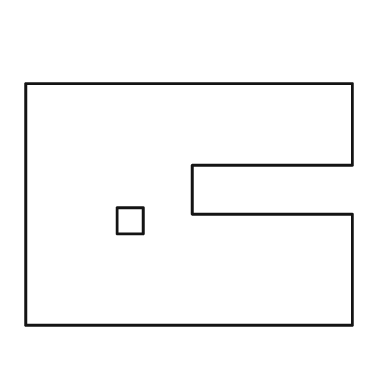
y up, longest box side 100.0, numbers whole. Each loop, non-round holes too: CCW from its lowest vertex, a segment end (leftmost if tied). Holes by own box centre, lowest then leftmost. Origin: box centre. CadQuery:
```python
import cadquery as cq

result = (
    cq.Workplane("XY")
    .moveTo(-50.0, -37.0)
    .lineTo(50.0, -37.0)
    .lineTo(50.0, -3.0)
    .lineTo(1.0, -3.0)
    .lineTo(1.0, 12.0)
    .lineTo(50.0, 12.0)
    .lineTo(50.0, 37.0)
    .lineTo(-50.0, 37.0)
    .close()
    .moveTo(-22.0, -9.0)
    .lineTo(-14.0, -9.0)
    .lineTo(-14.0, -1.0)
    .lineTo(-22.0, -1.0)
    .close()
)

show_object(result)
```